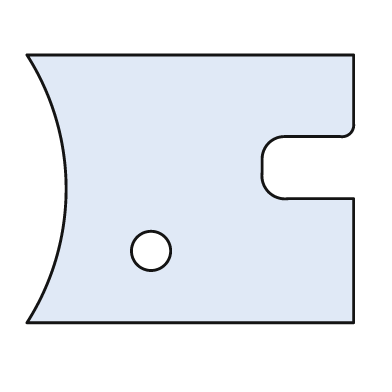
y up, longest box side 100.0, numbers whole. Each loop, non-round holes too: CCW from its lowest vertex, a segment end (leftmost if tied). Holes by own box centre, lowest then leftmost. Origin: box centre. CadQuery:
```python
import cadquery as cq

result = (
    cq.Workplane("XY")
    .moveTo(-50.0, -41.0)
    .lineTo(50.0, -41.0)
    .lineTo(50.0, -3.0)
    .lineTo(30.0, -3.0)
    .threePointArc((24.0, -1.0), (22.0, 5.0))
    .lineTo(22.0, 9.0)
    .threePointArc((24.0, 14.0), (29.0, 16.0))
    .lineTo(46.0, 16.0)
    .threePointArc((49.0, 17.0), (50.0, 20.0))
    .lineTo(50.0, 41.0)
    .lineTo(-50.0, 41.0)
    .threePointArc((-38.0, 0.0), (-50.0, -41.0))
    .close()
    .moveTo(-12.0, -19.0)
    .circle(6.0)
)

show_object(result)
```